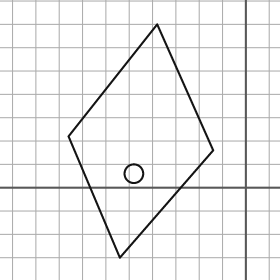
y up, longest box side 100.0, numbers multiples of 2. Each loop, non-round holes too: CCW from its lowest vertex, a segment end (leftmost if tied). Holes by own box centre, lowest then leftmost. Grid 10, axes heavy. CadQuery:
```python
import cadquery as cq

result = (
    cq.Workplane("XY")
    .moveTo(-54.0, -30.0)
    .lineTo(-14.0, 16.0)
    .lineTo(-38.0, 70.0)
    .lineTo(-76.0, 22.0)
    .close()
    .moveTo(-48.0, 6.0)
    .circle(4.0)
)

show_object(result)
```